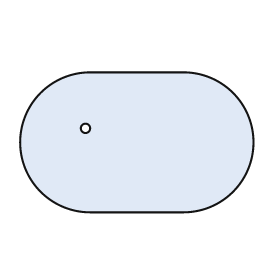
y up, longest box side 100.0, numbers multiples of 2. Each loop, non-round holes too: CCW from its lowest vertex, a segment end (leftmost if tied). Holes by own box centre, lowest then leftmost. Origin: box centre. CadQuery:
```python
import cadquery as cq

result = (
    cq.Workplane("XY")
    .moveTo(-20.0, -30.0)
    .lineTo(20.0, -30.0)
    .threePointArc((50.0, 0.0), (20.0, 30.0))
    .lineTo(-20.0, 30.0)
    .threePointArc((-50.0, 0.0), (-20.0, -30.0))
    .close()
    .moveTo(-22.0, 6.0)
    .circle(2.0)
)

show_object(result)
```